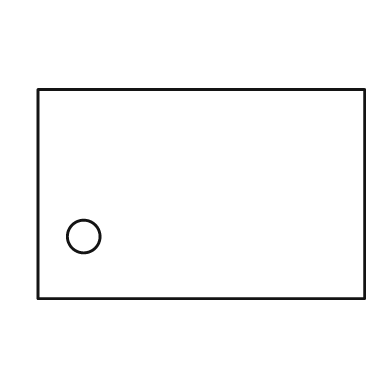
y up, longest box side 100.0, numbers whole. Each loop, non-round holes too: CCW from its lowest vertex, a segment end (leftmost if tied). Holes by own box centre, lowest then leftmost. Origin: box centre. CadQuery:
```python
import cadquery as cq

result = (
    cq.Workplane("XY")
    .moveTo(-50.0, -32.0)
    .lineTo(50.0, -32.0)
    .lineTo(50.0, 32.0)
    .lineTo(-50.0, 32.0)
    .close()
    .moveTo(-36.0, -13.0)
    .circle(5.0)
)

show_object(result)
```